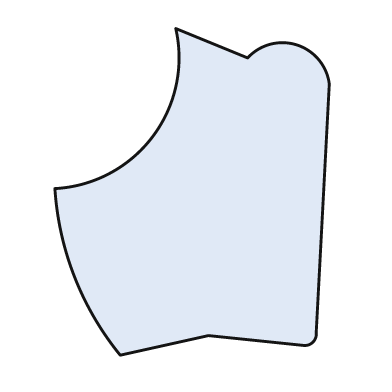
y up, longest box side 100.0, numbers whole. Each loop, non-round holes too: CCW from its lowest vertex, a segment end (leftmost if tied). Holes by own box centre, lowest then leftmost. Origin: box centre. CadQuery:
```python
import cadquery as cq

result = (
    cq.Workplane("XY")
    .moveTo(-22.0, -50.0)
    .lineTo(5.0, -44.0)
    .lineTo(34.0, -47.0)
    .threePointArc((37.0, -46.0), (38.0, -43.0))
    .lineTo(42.0, 33.0)
    .threePointArc((32.0, 45.0), (17.0, 41.0))
    .lineTo(-5.0, 50.0)
    .threePointArc((-12.0, 17.0), (-42.0, 1.0))
    .threePointArc((-36.0, -26.0), (-22.0, -50.0))
    .close()
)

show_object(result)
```